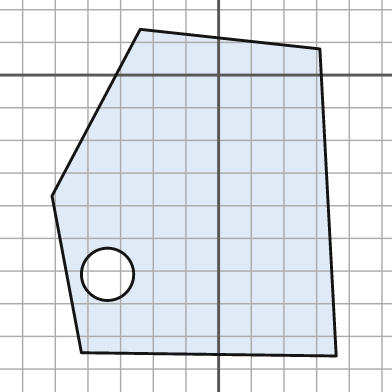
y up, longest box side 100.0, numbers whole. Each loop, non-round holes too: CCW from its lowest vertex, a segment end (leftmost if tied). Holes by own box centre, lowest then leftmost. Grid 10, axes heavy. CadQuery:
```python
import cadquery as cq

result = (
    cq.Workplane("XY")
    .moveTo(36.0, -86.0)
    .lineTo(31.0, 8.0)
    .lineTo(-24.0, 14.0)
    .lineTo(-51.0, -37.0)
    .lineTo(-42.0, -85.0)
    .close()
    .moveTo(-34.0, -61.0)
    .circle(8.0)
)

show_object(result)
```